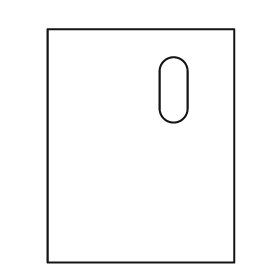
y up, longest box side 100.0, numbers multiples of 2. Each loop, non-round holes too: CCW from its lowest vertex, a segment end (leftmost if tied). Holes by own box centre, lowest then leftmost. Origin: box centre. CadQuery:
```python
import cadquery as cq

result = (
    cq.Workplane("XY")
    .moveTo(-40.0, -50.0)
    .lineTo(40.0, -50.0)
    .lineTo(40.0, 50.0)
    .lineTo(-40.0, 50.0)
    .close()
    .moveTo(8.0, 16.0)
    .threePointArc((14.0, 10.0), (20.0, 16.0))
    .lineTo(20.0, 32.0)
    .threePointArc((14.0, 38.0), (8.0, 32.0))
    .close()
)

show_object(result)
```